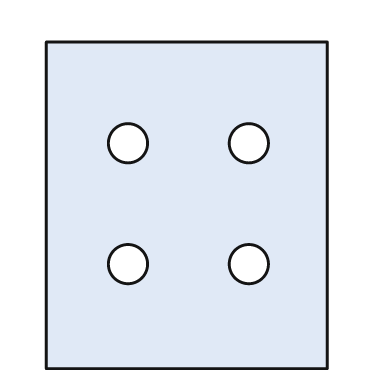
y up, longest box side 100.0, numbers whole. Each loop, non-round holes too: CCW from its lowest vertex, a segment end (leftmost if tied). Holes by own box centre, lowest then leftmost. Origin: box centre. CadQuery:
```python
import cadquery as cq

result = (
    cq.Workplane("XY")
    .moveTo(-43.0, -50.0)
    .lineTo(43.0, -50.0)
    .lineTo(43.0, 50.0)
    .lineTo(-43.0, 50.0)
    .close()
    .moveTo(-18.0, -18.0)
    .circle(6.0)
    .moveTo(19.0, -18.0)
    .circle(6.0)
    .moveTo(-18.0, 19.0)
    .circle(6.0)
    .moveTo(19.0, 19.0)
    .circle(6.0)
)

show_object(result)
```